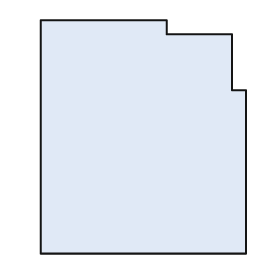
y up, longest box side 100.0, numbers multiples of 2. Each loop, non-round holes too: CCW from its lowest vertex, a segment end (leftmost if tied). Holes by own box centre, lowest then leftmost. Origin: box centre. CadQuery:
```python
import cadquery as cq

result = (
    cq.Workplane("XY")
    .moveTo(-44.0, -50.0)
    .lineTo(44.0, -50.0)
    .lineTo(44.0, 20.0)
    .lineTo(38.0, 20.0)
    .lineTo(38.0, 44.0)
    .lineTo(10.0, 44.0)
    .lineTo(10.0, 50.0)
    .lineTo(-44.0, 50.0)
    .close()
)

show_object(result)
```